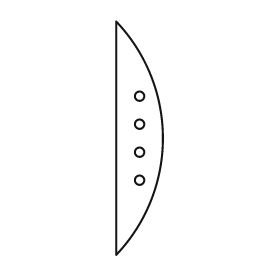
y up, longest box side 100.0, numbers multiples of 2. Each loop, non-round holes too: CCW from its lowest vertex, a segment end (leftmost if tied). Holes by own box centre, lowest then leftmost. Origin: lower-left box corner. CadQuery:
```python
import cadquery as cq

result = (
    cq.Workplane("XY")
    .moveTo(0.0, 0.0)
    .threePointArc((20.0, 50.0), (0.0, 100.0))
    .close()
    .moveTo(10.0, 32.0)
    .circle(2.0)
    .moveTo(10.0, 44.0)
    .circle(2.0)
    .moveTo(10.0, 56.0)
    .circle(2.0)
    .moveTo(10.0, 68.0)
    .circle(2.0)
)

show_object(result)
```